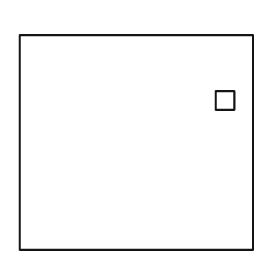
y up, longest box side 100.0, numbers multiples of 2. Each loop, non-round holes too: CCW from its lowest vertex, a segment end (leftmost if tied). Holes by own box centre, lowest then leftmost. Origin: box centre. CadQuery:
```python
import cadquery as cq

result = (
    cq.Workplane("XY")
    .moveTo(-50.0, -46.0)
    .lineTo(50.0, -46.0)
    .lineTo(50.0, 46.0)
    .lineTo(-50.0, 46.0)
    .close()
    .moveTo(34.0, 14.0)
    .lineTo(42.0, 14.0)
    .lineTo(42.0, 22.0)
    .lineTo(34.0, 22.0)
    .close()
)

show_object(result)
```